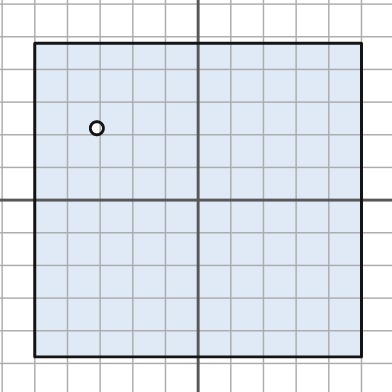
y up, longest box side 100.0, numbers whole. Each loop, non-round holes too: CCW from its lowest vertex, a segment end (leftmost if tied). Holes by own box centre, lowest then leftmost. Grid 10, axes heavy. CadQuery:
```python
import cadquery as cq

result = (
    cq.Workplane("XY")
    .moveTo(-50.0, -48.0)
    .lineTo(50.0, -48.0)
    .lineTo(50.0, 48.0)
    .lineTo(-50.0, 48.0)
    .close()
    .moveTo(-31.0, 22.0)
    .circle(2.0)
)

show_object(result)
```